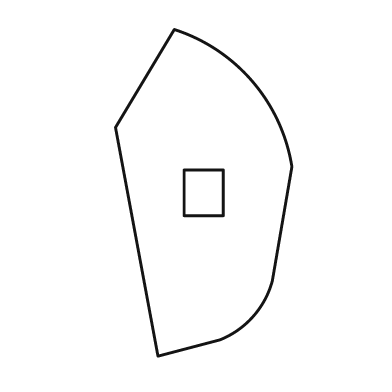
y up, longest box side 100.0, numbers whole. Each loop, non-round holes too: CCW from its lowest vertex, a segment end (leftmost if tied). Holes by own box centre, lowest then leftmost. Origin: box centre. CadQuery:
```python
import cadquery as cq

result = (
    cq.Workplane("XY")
    .moveTo(-14.0, -50.0)
    .lineTo(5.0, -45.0)
    .threePointArc((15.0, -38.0), (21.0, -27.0))
    .lineTo(27.0, 8.0)
    .threePointArc((15.0, 34.0), (-9.0, 50.0))
    .lineTo(-27.0, 20.0)
    .close()
    .moveTo(-6.0, -7.0)
    .lineTo(6.0, -7.0)
    .lineTo(6.0, 7.0)
    .lineTo(-6.0, 7.0)
    .close()
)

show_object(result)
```